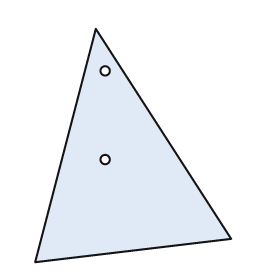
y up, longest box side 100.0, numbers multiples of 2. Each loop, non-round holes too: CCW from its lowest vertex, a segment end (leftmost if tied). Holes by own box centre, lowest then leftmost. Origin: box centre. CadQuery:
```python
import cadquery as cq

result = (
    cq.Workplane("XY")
    .moveTo(-42.0, -50.0)
    .lineTo(42.0, -40.0)
    .lineTo(-16.0, 50.0)
    .close()
    .moveTo(-12.0, -6.0)
    .circle(2.0)
    .moveTo(-12.0, 32.0)
    .circle(2.0)
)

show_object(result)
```